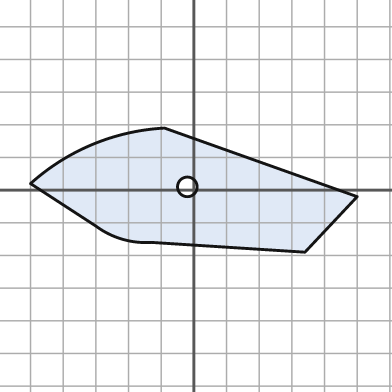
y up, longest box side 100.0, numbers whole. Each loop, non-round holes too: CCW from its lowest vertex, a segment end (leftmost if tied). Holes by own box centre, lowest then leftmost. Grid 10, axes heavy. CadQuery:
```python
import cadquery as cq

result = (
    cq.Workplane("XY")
    .moveTo(34.0, -19.0)
    .lineTo(50.0, -2.0)
    .lineTo(-9.0, 19.0)
    .threePointArc((-31.0, 14.0), (-50.0, 2.0))
    .lineTo(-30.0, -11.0)
    .threePointArc((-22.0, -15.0), (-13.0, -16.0))
    .close()
    .moveTo(-2.0, 1.0)
    .circle(3.0)
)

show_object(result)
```